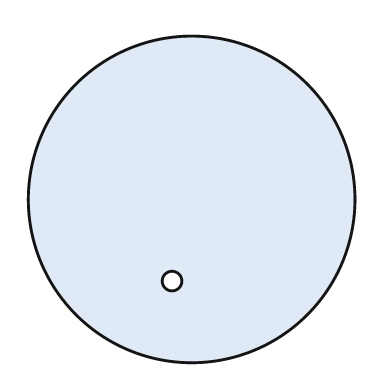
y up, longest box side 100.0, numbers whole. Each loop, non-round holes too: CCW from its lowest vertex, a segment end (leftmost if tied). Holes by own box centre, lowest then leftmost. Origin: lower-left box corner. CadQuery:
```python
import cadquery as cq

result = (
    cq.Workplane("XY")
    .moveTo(50.0, 50.0)
    .circle(50.0)
    .moveTo(44.0, 25.0)
    .circle(3.0)
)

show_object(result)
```